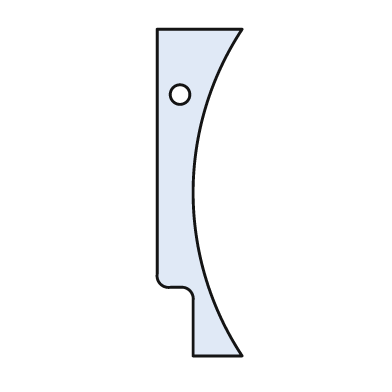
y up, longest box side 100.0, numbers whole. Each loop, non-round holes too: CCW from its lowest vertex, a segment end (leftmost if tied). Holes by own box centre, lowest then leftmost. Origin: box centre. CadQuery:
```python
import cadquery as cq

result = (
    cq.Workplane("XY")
    .moveTo(-2.0, -50.0)
    .lineTo(13.0, -50.0)
    .threePointArc((-2.0, 0.0), (13.0, 50.0))
    .lineTo(-13.0, 50.0)
    .lineTo(-13.0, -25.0)
    .threePointArc((-12.0, -28.0), (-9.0, -29.0))
    .lineTo(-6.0, -29.0)
    .threePointArc((-3.0, -30.0), (-2.0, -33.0))
    .close()
    .moveTo(-6.0, 30.0)
    .circle(3.0)
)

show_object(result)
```